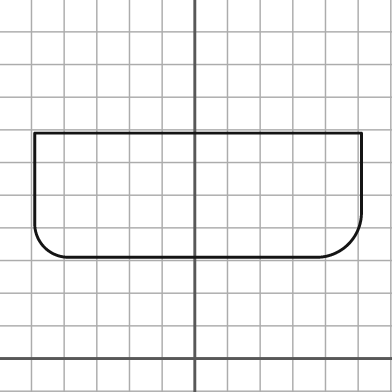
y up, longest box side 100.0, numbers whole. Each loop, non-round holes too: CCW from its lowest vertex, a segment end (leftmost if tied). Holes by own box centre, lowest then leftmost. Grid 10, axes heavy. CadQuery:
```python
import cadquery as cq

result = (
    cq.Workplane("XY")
    .moveTo(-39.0, 31.0)
    .lineTo(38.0, 31.0)
    .threePointArc((47.0, 35.0), (51.0, 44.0))
    .lineTo(51.0, 69.0)
    .lineTo(-49.0, 69.0)
    .lineTo(-49.0, 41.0)
    .threePointArc((-46.0, 34.0), (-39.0, 31.0))
    .close()
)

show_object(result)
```